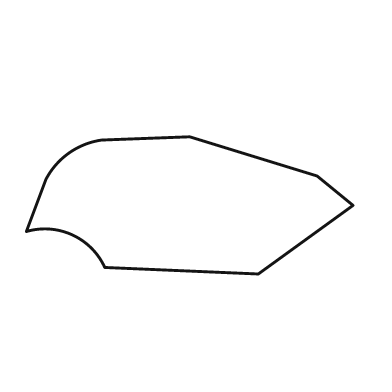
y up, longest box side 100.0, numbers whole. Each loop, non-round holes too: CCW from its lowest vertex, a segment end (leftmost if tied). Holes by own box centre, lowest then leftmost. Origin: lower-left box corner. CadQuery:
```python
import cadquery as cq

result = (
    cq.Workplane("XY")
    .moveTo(71.0, 0.0)
    .lineTo(100.0, 21.0)
    .lineTo(89.0, 30.0)
    .lineTo(50.0, 42.0)
    .lineTo(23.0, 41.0)
    .threePointArc((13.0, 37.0), (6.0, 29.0))
    .lineTo(0.0, 13.0)
    .threePointArc((14.0, 12.0), (24.0, 2.0))
    .close()
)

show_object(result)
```